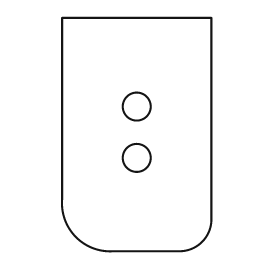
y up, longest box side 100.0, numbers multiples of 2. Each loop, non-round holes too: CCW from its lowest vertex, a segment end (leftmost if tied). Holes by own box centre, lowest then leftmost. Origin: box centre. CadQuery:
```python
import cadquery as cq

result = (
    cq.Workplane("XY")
    .moveTo(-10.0, -50.0)
    .lineTo(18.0, -50.0)
    .threePointArc((28.0, -46.0), (32.0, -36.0))
    .lineTo(32.0, 50.0)
    .lineTo(-32.0, 50.0)
    .lineTo(-32.0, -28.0)
    .threePointArc((-26.0, -44.0), (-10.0, -50.0))
    .close()
    .moveTo(0.0, -10.0)
    .circle(6.0)
    .moveTo(0.0, 12.0)
    .circle(6.0)
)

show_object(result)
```